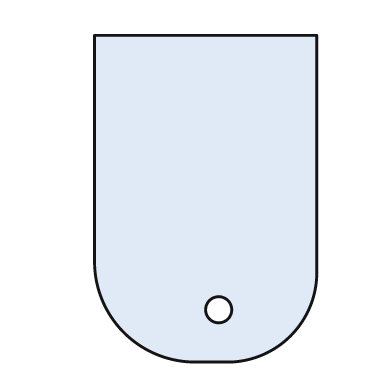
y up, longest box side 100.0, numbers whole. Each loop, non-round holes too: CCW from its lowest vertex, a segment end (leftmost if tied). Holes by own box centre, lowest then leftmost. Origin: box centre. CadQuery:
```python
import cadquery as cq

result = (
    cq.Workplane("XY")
    .moveTo(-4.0, -50.0)
    .lineTo(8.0, -50.0)
    .threePointArc((26.0, -42.0), (34.0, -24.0))
    .lineTo(34.0, 50.0)
    .lineTo(-34.0, 50.0)
    .lineTo(-34.0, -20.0)
    .threePointArc((-25.0, -41.0), (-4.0, -50.0))
    .close()
    .moveTo(4.0, -34.0)
    .circle(4.0)
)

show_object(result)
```